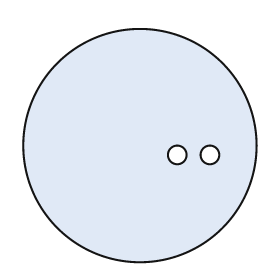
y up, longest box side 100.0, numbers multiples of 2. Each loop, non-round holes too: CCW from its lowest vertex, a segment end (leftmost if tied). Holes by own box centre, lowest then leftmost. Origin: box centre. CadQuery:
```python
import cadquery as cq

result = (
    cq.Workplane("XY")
    .moveTo(0.0, 0.0)
    .circle(50.0)
    .moveTo(16.0, -4.0)
    .circle(4.0)
    .moveTo(30.0, -4.0)
    .circle(4.0)
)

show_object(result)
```